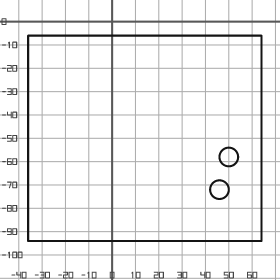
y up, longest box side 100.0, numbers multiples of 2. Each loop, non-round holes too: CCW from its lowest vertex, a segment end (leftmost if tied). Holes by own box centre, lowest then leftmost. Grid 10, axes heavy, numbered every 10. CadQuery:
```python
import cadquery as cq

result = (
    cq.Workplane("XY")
    .moveTo(-36.0, -94.0)
    .lineTo(64.0, -94.0)
    .lineTo(64.0, -6.0)
    .lineTo(-36.0, -6.0)
    .close()
    .moveTo(46.0, -72.0)
    .circle(4.0)
    .moveTo(50.0, -58.0)
    .circle(4.0)
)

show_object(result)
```